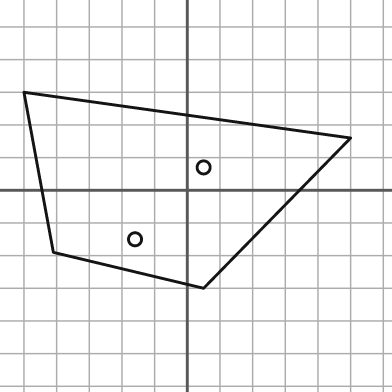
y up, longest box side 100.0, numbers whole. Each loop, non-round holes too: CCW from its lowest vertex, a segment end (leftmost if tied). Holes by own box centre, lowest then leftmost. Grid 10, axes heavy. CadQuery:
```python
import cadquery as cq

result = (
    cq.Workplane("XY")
    .moveTo(5.0, -30.0)
    .lineTo(50.0, 16.0)
    .lineTo(-50.0, 30.0)
    .lineTo(-41.0, -19.0)
    .close()
    .moveTo(-16.0, -15.0)
    .circle(2.0)
    .moveTo(5.0, 7.0)
    .circle(2.0)
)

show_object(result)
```